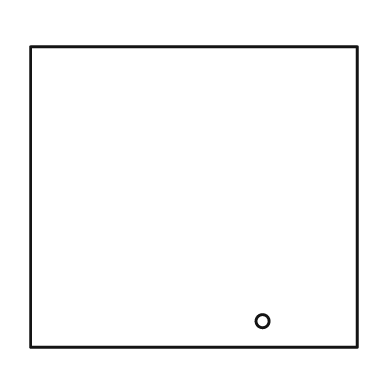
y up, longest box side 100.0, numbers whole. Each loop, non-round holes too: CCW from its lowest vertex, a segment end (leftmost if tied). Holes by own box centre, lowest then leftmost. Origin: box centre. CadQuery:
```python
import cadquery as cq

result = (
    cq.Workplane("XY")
    .moveTo(-50.0, -46.0)
    .lineTo(50.0, -46.0)
    .lineTo(50.0, 46.0)
    .lineTo(-50.0, 46.0)
    .close()
    .moveTo(21.0, -38.0)
    .circle(2.0)
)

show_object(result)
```